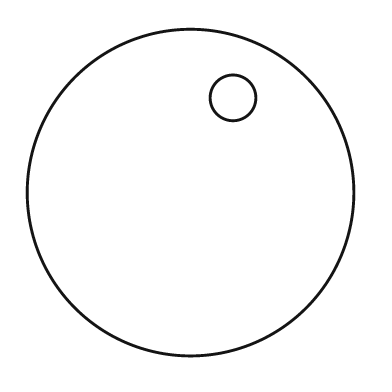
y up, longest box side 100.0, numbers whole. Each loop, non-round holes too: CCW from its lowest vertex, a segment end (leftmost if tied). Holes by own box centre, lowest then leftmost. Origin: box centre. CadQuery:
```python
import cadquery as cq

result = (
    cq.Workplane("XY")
    .moveTo(0.0, 0.0)
    .circle(50.0)
    .moveTo(13.0, 29.0)
    .circle(7.0)
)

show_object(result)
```